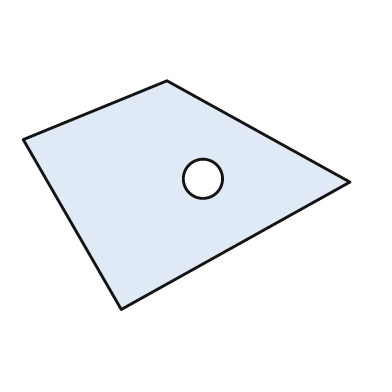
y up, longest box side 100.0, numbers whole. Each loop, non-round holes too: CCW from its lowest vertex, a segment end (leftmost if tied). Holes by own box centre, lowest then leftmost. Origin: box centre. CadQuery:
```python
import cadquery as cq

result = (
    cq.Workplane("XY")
    .moveTo(-20.0, -35.0)
    .lineTo(50.0, 4.0)
    .lineTo(-6.0, 35.0)
    .lineTo(-50.0, 17.0)
    .close()
    .moveTo(5.0, 5.0)
    .circle(6.0)
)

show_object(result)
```